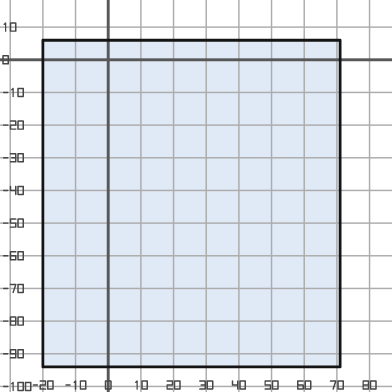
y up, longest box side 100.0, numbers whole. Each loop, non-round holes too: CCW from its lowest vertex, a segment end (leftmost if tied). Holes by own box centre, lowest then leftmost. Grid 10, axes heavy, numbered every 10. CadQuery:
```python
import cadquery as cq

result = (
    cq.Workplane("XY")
    .moveTo(-20.0, -94.0)
    .lineTo(71.0, -94.0)
    .lineTo(71.0, 6.0)
    .lineTo(-20.0, 6.0)
    .close()
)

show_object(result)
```